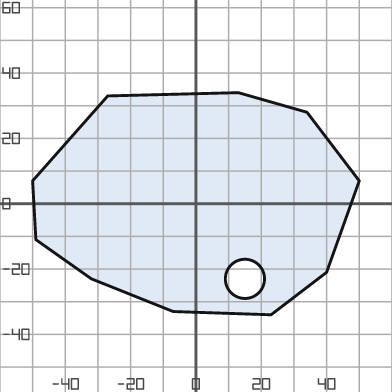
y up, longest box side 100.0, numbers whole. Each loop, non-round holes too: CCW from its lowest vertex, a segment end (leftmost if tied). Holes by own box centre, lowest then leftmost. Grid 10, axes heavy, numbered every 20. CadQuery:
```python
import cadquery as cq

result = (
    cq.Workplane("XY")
    .moveTo(23.0, -34.0)
    .lineTo(40.0, -21.0)
    .lineTo(50.0, 7.0)
    .lineTo(34.0, 28.0)
    .lineTo(13.0, 34.0)
    .lineTo(-27.0, 33.0)
    .lineTo(-50.0, 7.0)
    .lineTo(-49.0, -11.0)
    .lineTo(-32.0, -23.0)
    .lineTo(-7.0, -33.0)
    .close()
    .moveTo(15.0, -23.0)
    .circle(6.0)
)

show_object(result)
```